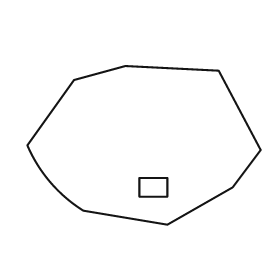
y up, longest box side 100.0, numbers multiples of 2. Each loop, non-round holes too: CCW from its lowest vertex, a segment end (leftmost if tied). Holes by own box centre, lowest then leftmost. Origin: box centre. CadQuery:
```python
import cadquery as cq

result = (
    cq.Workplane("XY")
    .moveTo(10.0, -34.0)
    .lineTo(38.0, -18.0)
    .lineTo(50.0, -2.0)
    .lineTo(32.0, 32.0)
    .lineTo(-8.0, 34.0)
    .lineTo(-30.0, 28.0)
    .lineTo(-50.0, 0.0)
    .threePointArc((-40.0, -16.0), (-26.0, -28.0))
    .close()
    .moveTo(-2.0, -22.0)
    .lineTo(10.0, -22.0)
    .lineTo(10.0, -14.0)
    .lineTo(-2.0, -14.0)
    .close()
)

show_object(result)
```